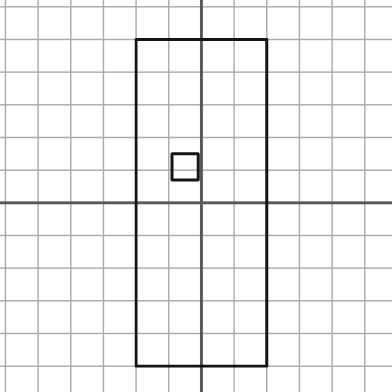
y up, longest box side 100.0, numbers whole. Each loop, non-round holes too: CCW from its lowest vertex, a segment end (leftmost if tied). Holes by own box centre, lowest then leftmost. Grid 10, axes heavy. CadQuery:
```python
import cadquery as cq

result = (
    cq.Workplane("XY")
    .moveTo(-20.0, -50.0)
    .lineTo(20.0, -50.0)
    .lineTo(20.0, 50.0)
    .lineTo(-20.0, 50.0)
    .close()
    .moveTo(-9.0, 7.0)
    .lineTo(-1.0, 7.0)
    .lineTo(-1.0, 15.0)
    .lineTo(-9.0, 15.0)
    .close()
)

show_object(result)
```